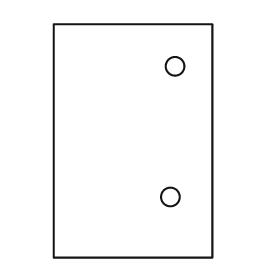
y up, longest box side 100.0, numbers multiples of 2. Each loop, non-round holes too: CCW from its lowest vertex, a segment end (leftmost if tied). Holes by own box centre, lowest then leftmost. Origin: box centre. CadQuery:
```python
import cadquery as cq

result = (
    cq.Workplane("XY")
    .moveTo(-34.0, -50.0)
    .lineTo(34.0, -50.0)
    .lineTo(34.0, 50.0)
    .lineTo(-34.0, 50.0)
    .close()
    .moveTo(16.0, -24.0)
    .circle(4.0)
    .moveTo(18.0, 32.0)
    .circle(4.0)
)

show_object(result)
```